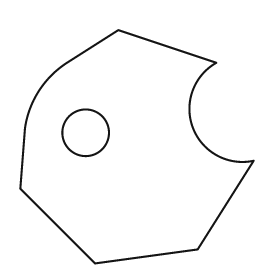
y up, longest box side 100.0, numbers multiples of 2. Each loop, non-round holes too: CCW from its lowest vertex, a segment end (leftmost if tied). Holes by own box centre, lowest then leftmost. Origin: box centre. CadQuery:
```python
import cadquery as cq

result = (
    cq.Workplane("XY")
    .moveTo(-18.0, -50.0)
    .lineTo(26.0, -44.0)
    .lineTo(50.0, -6.0)
    .threePointArc((24.0, 8.0), (34.0, 36.0))
    .lineTo(-8.0, 50.0)
    .lineTo(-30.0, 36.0)
    .threePointArc((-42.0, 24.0), (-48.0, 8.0))
    .lineTo(-50.0, -18.0)
    .close()
    .moveTo(-22.0, 6.0)
    .circle(10.0)
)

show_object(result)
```